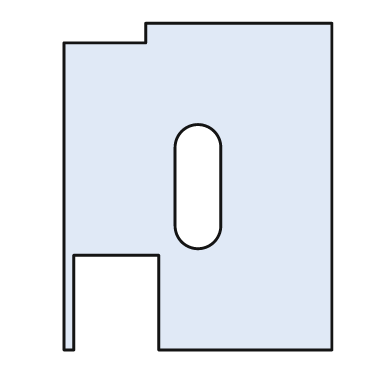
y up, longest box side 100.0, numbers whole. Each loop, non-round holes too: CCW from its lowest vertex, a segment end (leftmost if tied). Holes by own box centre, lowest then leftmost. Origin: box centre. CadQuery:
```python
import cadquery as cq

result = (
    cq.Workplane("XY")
    .moveTo(-41.0, -50.0)
    .lineTo(-38.0, -50.0)
    .lineTo(-38.0, -21.0)
    .lineTo(-12.0, -21.0)
    .lineTo(-12.0, -50.0)
    .lineTo(41.0, -50.0)
    .lineTo(41.0, 50.0)
    .lineTo(-16.0, 50.0)
    .lineTo(-16.0, 44.0)
    .lineTo(-41.0, 44.0)
    .close()
    .moveTo(-7.0, -12.0)
    .threePointArc((0.0, -19.0), (7.0, -12.0))
    .lineTo(7.0, 12.0)
    .threePointArc((0.0, 19.0), (-7.0, 12.0))
    .close()
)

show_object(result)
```